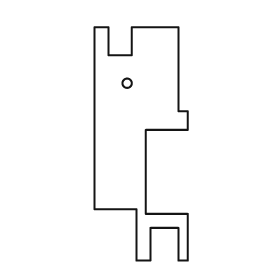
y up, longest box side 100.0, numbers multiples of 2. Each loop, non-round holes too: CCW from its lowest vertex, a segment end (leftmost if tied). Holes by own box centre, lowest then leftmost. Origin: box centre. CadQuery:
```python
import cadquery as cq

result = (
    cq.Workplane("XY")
    .moveTo(-2.0, -50.0)
    .lineTo(4.0, -50.0)
    .lineTo(4.0, -36.0)
    .lineTo(16.0, -36.0)
    .lineTo(16.0, -50.0)
    .lineTo(20.0, -50.0)
    .lineTo(20.0, -30.0)
    .lineTo(2.0, -30.0)
    .lineTo(2.0, 6.0)
    .lineTo(20.0, 6.0)
    .lineTo(20.0, 14.0)
    .lineTo(16.0, 14.0)
    .lineTo(16.0, 50.0)
    .lineTo(-4.0, 50.0)
    .lineTo(-4.0, 38.0)
    .lineTo(-14.0, 38.0)
    .lineTo(-14.0, 50.0)
    .lineTo(-20.0, 50.0)
    .lineTo(-20.0, -28.0)
    .lineTo(-2.0, -28.0)
    .close()
    .moveTo(-6.0, 26.0)
    .circle(2.0)
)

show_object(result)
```